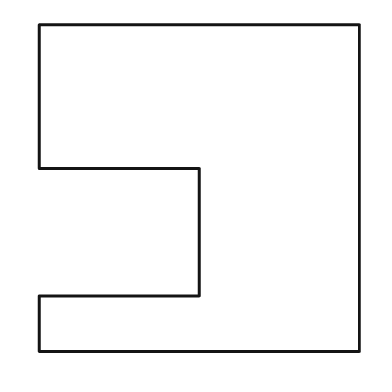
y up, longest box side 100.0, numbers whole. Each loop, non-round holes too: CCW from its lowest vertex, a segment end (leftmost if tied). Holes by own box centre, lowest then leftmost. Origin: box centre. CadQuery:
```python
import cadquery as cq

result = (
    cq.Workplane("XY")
    .moveTo(-49.0, -50.0)
    .lineTo(49.0, -50.0)
    .lineTo(49.0, 50.0)
    .lineTo(-49.0, 50.0)
    .lineTo(-49.0, 6.0)
    .lineTo(0.0, 6.0)
    .lineTo(0.0, -33.0)
    .lineTo(-49.0, -33.0)
    .close()
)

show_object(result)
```